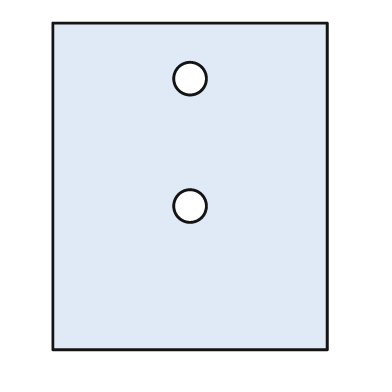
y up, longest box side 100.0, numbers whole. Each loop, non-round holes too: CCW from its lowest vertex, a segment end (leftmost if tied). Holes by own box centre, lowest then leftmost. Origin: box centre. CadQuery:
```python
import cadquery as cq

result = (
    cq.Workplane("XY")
    .moveTo(-42.0, -50.0)
    .lineTo(42.0, -50.0)
    .lineTo(42.0, 50.0)
    .lineTo(-42.0, 50.0)
    .close()
    .moveTo(0.0, -6.0)
    .circle(5.0)
    .moveTo(0.0, 33.0)
    .circle(5.0)
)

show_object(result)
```